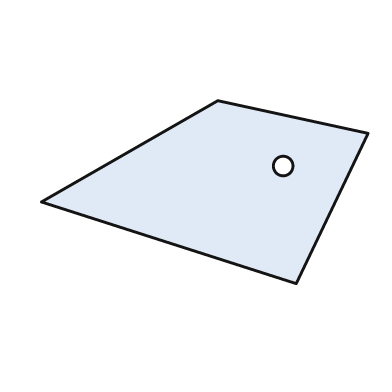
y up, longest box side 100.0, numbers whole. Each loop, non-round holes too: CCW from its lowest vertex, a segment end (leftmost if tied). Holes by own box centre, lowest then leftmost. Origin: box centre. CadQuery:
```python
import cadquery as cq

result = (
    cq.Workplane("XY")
    .moveTo(28.0, -28.0)
    .lineTo(50.0, 18.0)
    .lineTo(4.0, 28.0)
    .lineTo(-50.0, -3.0)
    .close()
    .moveTo(24.0, 8.0)
    .circle(3.0)
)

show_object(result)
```